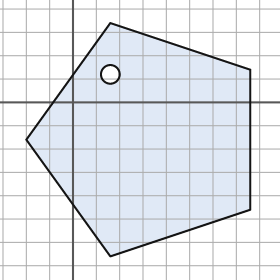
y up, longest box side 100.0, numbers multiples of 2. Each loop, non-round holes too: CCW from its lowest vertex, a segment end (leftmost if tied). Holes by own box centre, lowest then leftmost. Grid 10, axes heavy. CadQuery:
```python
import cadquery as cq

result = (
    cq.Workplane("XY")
    .moveTo(16.0, -66.0)
    .lineTo(76.0, -46.0)
    .lineTo(76.0, 14.0)
    .lineTo(16.0, 34.0)
    .lineTo(-20.0, -16.0)
    .close()
    .moveTo(16.0, 12.0)
    .circle(4.0)
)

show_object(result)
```